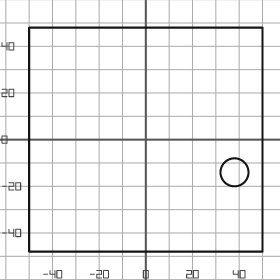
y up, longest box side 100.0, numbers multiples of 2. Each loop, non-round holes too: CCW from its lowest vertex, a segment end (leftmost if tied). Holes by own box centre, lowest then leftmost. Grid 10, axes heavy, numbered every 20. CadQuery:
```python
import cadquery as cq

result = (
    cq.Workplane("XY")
    .moveTo(-50.0, -48.0)
    .lineTo(50.0, -48.0)
    .lineTo(50.0, 48.0)
    .lineTo(-50.0, 48.0)
    .close()
    .moveTo(38.0, -14.0)
    .circle(6.0)
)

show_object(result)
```